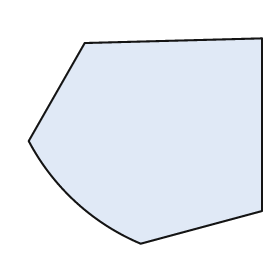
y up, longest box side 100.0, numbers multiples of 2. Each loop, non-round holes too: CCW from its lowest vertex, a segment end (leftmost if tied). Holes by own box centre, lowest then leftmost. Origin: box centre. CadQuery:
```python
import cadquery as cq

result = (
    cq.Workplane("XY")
    .moveTo(-2.0, -44.0)
    .lineTo(50.0, -30.0)
    .lineTo(50.0, 44.0)
    .lineTo(-26.0, 42.0)
    .lineTo(-50.0, 0.0)
    .threePointArc((-30.0, -26.0), (-2.0, -44.0))
    .close()
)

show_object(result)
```